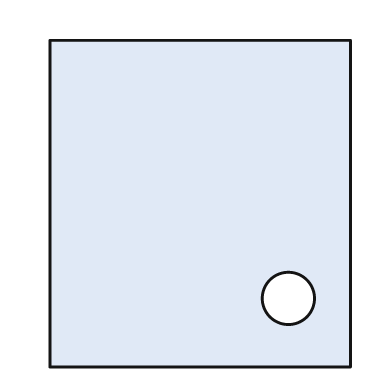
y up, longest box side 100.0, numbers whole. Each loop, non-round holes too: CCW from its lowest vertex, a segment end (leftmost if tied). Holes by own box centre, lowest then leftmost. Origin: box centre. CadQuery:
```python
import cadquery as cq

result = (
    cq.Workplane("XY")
    .moveTo(-46.0, -50.0)
    .lineTo(46.0, -50.0)
    .lineTo(46.0, 50.0)
    .lineTo(-46.0, 50.0)
    .close()
    .moveTo(27.0, -29.0)
    .circle(8.0)
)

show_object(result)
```